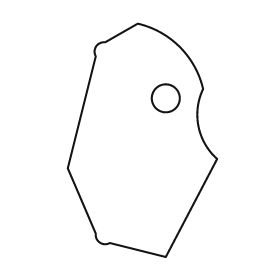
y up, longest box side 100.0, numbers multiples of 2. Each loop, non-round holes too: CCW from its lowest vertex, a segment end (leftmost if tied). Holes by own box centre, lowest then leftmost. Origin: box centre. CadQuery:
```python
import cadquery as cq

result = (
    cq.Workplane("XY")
    .moveTo(10.0, -50.0)
    .lineTo(32.0, -8.0)
    .threePointArc((24.0, 6.0), (26.0, 22.0))
    .threePointArc((16.0, 40.0), (-2.0, 50.0))
    .lineTo(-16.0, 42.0)
    .threePointArc((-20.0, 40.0), (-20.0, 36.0))
    .lineTo(-32.0, -12.0)
    .lineTo(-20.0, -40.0)
    .threePointArc((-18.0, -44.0), (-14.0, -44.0))
    .close()
    .moveTo(10.0, 18.0)
    .circle(6.0)
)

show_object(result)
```